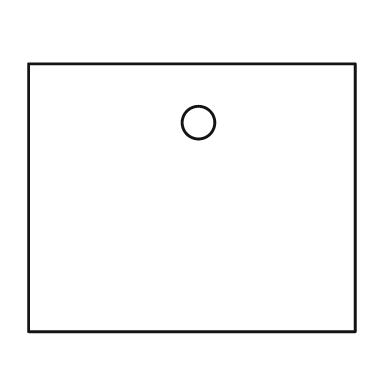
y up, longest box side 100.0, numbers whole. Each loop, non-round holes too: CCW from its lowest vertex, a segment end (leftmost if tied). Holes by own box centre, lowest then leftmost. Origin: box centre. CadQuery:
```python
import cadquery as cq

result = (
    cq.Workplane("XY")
    .moveTo(-50.0, -41.0)
    .lineTo(50.0, -41.0)
    .lineTo(50.0, 41.0)
    .lineTo(-50.0, 41.0)
    .close()
    .moveTo(2.0, 23.0)
    .circle(5.0)
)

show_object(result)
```